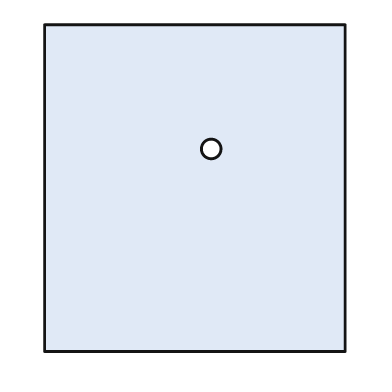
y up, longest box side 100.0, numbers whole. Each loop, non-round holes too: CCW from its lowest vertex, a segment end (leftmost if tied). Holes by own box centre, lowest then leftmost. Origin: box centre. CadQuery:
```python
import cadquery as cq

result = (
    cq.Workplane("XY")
    .moveTo(-46.0, -50.0)
    .lineTo(46.0, -50.0)
    .lineTo(46.0, 50.0)
    .lineTo(-46.0, 50.0)
    .close()
    .moveTo(5.0, 12.0)
    .circle(3.0)
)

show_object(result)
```